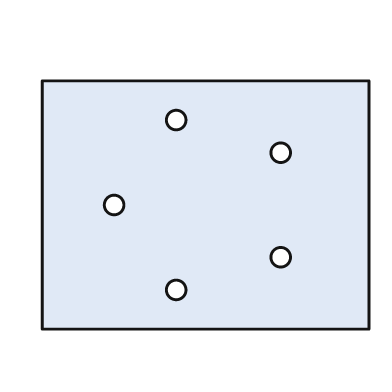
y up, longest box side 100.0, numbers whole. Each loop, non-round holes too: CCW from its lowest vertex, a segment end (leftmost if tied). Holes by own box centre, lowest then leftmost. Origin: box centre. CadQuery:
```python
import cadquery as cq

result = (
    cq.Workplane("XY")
    .moveTo(-50.0, -38.0)
    .lineTo(50.0, -38.0)
    .lineTo(50.0, 38.0)
    .lineTo(-50.0, 38.0)
    .close()
    .moveTo(-9.0, -26.0)
    .circle(3.0)
    .moveTo(23.0, -16.0)
    .circle(3.0)
    .moveTo(-28.0, 0.0)
    .circle(3.0)
    .moveTo(23.0, 16.0)
    .circle(3.0)
    .moveTo(-9.0, 26.0)
    .circle(3.0)
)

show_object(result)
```